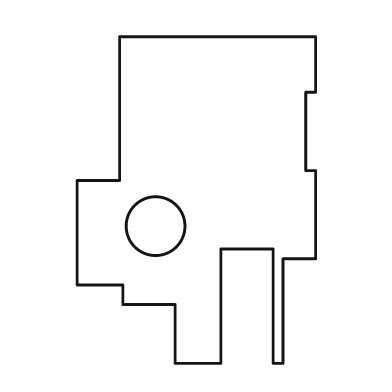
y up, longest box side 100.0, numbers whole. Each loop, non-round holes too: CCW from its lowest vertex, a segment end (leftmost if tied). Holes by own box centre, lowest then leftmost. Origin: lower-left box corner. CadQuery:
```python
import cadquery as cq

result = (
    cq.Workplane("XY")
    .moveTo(30.0, 0.0)
    .lineTo(44.0, 0.0)
    .lineTo(44.0, 35.0)
    .lineTo(60.0, 35.0)
    .lineTo(60.0, 0.0)
    .lineTo(63.0, 0.0)
    .lineTo(63.0, 32.0)
    .lineTo(73.0, 32.0)
    .lineTo(73.0, 59.0)
    .lineTo(70.0, 59.0)
    .lineTo(70.0, 83.0)
    .lineTo(73.0, 83.0)
    .lineTo(73.0, 100.0)
    .lineTo(13.0, 100.0)
    .lineTo(13.0, 56.0)
    .lineTo(0.0, 56.0)
    .lineTo(0.0, 24.0)
    .lineTo(14.0, 24.0)
    .lineTo(14.0, 18.0)
    .lineTo(30.0, 18.0)
    .close()
    .moveTo(24.0, 42.0)
    .circle(9.0)
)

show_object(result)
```